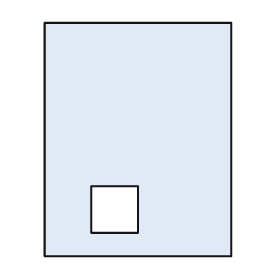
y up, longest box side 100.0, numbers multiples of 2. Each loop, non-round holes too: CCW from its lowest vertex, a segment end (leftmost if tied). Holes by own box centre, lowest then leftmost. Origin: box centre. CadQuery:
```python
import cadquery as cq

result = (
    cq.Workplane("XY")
    .moveTo(-40.0, -50.0)
    .lineTo(40.0, -50.0)
    .lineTo(40.0, 50.0)
    .lineTo(-40.0, 50.0)
    .close()
    .moveTo(-20.0, -40.0)
    .lineTo(0.0, -40.0)
    .lineTo(0.0, -20.0)
    .lineTo(-20.0, -20.0)
    .close()
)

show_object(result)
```